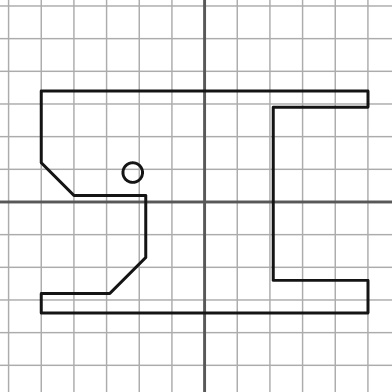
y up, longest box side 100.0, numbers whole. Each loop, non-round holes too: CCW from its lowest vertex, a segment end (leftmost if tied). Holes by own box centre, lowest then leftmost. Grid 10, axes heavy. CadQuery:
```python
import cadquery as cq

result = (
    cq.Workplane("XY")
    .moveTo(-50.0, -34.0)
    .lineTo(50.0, -34.0)
    .lineTo(50.0, -24.0)
    .lineTo(21.0, -24.0)
    .lineTo(21.0, 29.0)
    .lineTo(50.0, 29.0)
    .lineTo(50.0, 34.0)
    .lineTo(-50.0, 34.0)
    .lineTo(-50.0, 12.0)
    .lineTo(-40.0, 2.0)
    .lineTo(-18.0, 2.0)
    .lineTo(-18.0, -17.0)
    .lineTo(-29.0, -28.0)
    .lineTo(-50.0, -28.0)
    .close()
    .moveTo(-22.0, 9.0)
    .circle(3.0)
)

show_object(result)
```